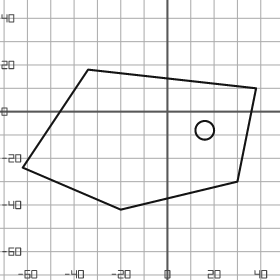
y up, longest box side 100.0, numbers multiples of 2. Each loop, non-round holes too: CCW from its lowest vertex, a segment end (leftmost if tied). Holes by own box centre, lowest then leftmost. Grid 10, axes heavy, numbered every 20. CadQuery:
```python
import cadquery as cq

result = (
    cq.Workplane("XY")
    .moveTo(-20.0, -42.0)
    .lineTo(30.0, -30.0)
    .lineTo(38.0, 10.0)
    .lineTo(-34.0, 18.0)
    .lineTo(-62.0, -24.0)
    .close()
    .moveTo(16.0, -8.0)
    .circle(4.0)
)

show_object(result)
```